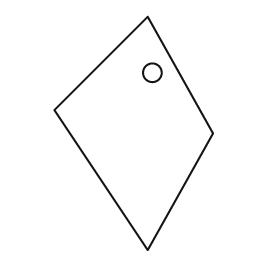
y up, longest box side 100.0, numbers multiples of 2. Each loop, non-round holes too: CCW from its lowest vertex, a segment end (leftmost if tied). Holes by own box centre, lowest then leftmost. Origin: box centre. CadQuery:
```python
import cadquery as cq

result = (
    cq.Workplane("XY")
    .moveTo(6.0, -50.0)
    .lineTo(34.0, 0.0)
    .lineTo(6.0, 50.0)
    .lineTo(-34.0, 10.0)
    .close()
    .moveTo(8.0, 26.0)
    .circle(4.0)
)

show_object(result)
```